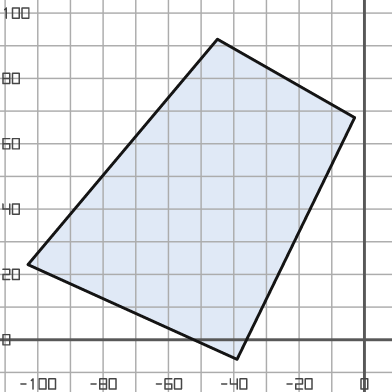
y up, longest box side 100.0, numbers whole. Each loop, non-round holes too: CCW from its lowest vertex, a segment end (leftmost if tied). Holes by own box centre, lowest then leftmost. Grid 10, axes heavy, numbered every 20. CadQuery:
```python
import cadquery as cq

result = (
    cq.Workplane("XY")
    .moveTo(-39.0, -6.0)
    .lineTo(-3.0, 68.0)
    .lineTo(-45.0, 92.0)
    .lineTo(-103.0, 23.0)
    .close()
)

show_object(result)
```